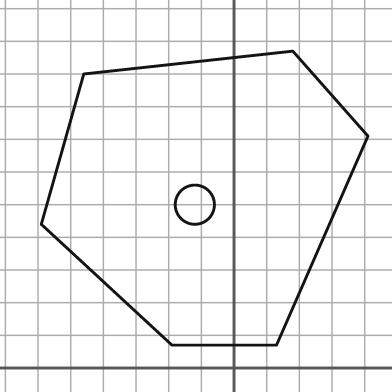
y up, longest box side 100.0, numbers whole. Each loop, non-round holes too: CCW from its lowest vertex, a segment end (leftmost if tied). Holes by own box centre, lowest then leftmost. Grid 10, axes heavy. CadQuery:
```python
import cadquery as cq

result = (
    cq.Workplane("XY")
    .moveTo(-19.0, 7.0)
    .lineTo(13.0, 7.0)
    .lineTo(41.0, 71.0)
    .lineTo(18.0, 97.0)
    .lineTo(-46.0, 90.0)
    .lineTo(-59.0, 44.0)
    .close()
    .moveTo(-12.0, 50.0)
    .circle(6.0)
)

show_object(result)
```